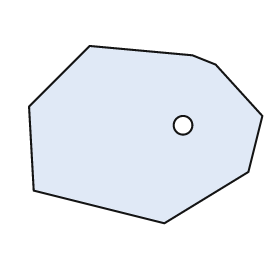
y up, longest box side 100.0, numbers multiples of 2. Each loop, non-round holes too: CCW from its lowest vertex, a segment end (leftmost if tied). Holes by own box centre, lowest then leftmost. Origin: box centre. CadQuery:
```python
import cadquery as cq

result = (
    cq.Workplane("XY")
    .moveTo(8.0, -38.0)
    .lineTo(44.0, -16.0)
    .lineTo(50.0, 8.0)
    .lineTo(30.0, 30.0)
    .lineTo(20.0, 34.0)
    .lineTo(-24.0, 38.0)
    .lineTo(-50.0, 12.0)
    .lineTo(-48.0, -24.0)
    .close()
    .moveTo(16.0, 4.0)
    .circle(4.0)
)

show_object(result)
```